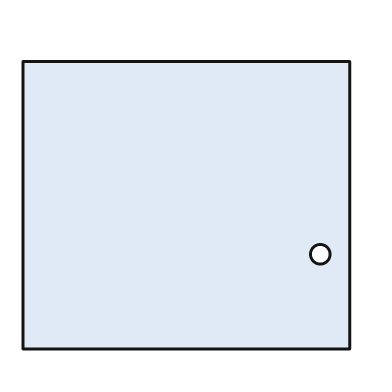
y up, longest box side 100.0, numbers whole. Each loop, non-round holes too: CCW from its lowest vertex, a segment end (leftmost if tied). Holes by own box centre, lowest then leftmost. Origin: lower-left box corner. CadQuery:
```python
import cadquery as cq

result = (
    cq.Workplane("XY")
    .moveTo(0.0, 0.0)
    .lineTo(100.0, 0.0)
    .lineTo(100.0, 88.0)
    .lineTo(0.0, 88.0)
    .close()
    .moveTo(91.0, 29.0)
    .circle(3.0)
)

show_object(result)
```